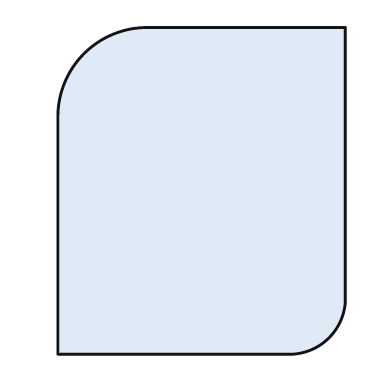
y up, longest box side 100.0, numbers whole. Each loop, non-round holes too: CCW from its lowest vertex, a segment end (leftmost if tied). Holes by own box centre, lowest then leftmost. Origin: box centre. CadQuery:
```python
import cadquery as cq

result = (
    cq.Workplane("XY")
    .moveTo(-44.0, -50.0)
    .lineTo(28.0, -50.0)
    .threePointArc((39.0, -45.0), (44.0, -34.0))
    .lineTo(44.0, 50.0)
    .lineTo(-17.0, 50.0)
    .threePointArc((-36.0, 42.0), (-44.0, 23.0))
    .close()
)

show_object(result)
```